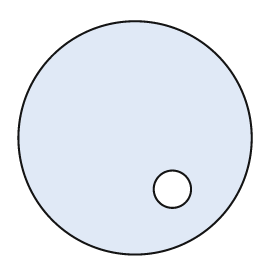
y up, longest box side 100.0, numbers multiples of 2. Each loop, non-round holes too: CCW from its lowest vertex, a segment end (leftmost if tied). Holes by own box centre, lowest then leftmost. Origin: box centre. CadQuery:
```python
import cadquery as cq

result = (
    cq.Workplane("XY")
    .moveTo(0.0, 0.0)
    .circle(50.0)
    .moveTo(16.0, -22.0)
    .circle(8.0)
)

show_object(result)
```